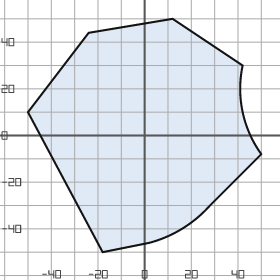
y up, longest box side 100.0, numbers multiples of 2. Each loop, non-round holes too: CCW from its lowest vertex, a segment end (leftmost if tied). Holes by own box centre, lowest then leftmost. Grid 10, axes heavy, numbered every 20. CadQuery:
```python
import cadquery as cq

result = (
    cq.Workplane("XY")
    .moveTo(-18.0, -50.0)
    .lineTo(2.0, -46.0)
    .threePointArc((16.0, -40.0), (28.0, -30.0))
    .lineTo(50.0, -8.0)
    .threePointArc((42.0, 10.0), (42.0, 30.0))
    .lineTo(12.0, 50.0)
    .lineTo(-24.0, 44.0)
    .lineTo(-50.0, 10.0)
    .close()
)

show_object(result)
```